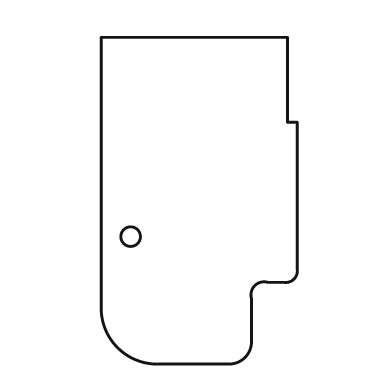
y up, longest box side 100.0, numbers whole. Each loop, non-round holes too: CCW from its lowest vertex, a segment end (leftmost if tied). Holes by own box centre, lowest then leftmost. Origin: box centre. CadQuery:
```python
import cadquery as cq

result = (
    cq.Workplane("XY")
    .moveTo(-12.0, -50.0)
    .lineTo(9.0, -50.0)
    .threePointArc((14.0, -48.0), (16.0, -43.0))
    .lineTo(16.0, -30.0)
    .threePointArc((17.0, -26.0), (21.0, -25.0))
    .lineTo(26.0, -25.0)
    .threePointArc((29.0, -24.0), (30.0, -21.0))
    .lineTo(30.0, 24.0)
    .lineTo(27.0, 24.0)
    .lineTo(27.0, 50.0)
    .lineTo(-30.0, 50.0)
    .lineTo(-30.0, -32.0)
    .threePointArc((-25.0, -45.0), (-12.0, -50.0))
    .close()
    .moveTo(-21.0, -11.0)
    .circle(3.0)
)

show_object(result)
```